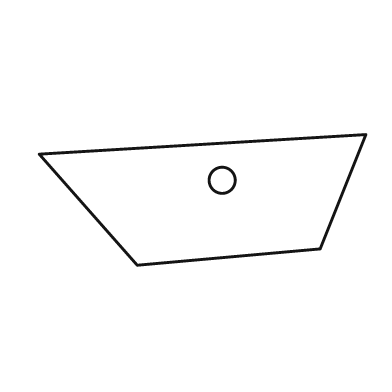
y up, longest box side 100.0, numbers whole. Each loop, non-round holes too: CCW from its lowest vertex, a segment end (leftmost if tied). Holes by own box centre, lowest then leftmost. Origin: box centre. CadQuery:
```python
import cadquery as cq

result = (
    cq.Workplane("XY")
    .moveTo(-20.0, -20.0)
    .lineTo(36.0, -15.0)
    .lineTo(50.0, 20.0)
    .lineTo(-50.0, 14.0)
    .close()
    .moveTo(6.0, 6.0)
    .circle(4.0)
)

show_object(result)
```